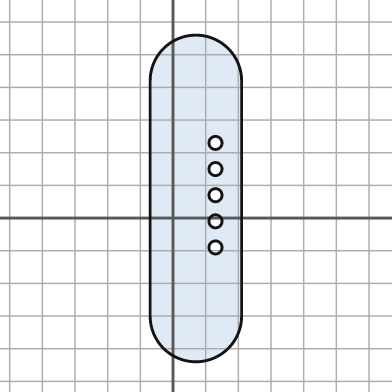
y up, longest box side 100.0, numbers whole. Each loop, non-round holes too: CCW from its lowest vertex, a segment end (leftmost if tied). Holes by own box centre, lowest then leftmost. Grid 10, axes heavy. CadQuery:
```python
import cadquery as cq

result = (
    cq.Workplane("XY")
    .moveTo(-7.0, -30.0)
    .threePointArc((7.0, -44.0), (21.0, -30.0))
    .lineTo(21.0, 42.0)
    .threePointArc((7.0, 56.0), (-7.0, 42.0))
    .close()
    .moveTo(13.0, -9.0)
    .circle(2.0)
    .moveTo(13.0, -1.0)
    .circle(2.0)
    .moveTo(13.0, 7.0)
    .circle(2.0)
    .moveTo(13.0, 15.0)
    .circle(2.0)
    .moveTo(13.0, 23.0)
    .circle(2.0)
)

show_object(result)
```